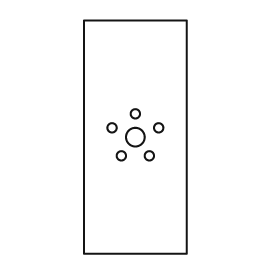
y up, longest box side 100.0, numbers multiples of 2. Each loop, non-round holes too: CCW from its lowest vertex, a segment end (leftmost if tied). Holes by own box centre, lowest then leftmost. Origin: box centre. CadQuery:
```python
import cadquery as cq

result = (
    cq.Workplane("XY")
    .moveTo(-22.0, -50.0)
    .lineTo(22.0, -50.0)
    .lineTo(22.0, 50.0)
    .lineTo(-22.0, 50.0)
    .close()
    .moveTo(-6.0, -8.0)
    .circle(2.0)
    .moveTo(6.0, -8.0)
    .circle(2.0)
    .moveTo(0.0, 0.0)
    .circle(4.0)
    .moveTo(-10.0, 4.0)
    .circle(2.0)
    .moveTo(10.0, 4.0)
    .circle(2.0)
    .moveTo(0.0, 10.0)
    .circle(2.0)
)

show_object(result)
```